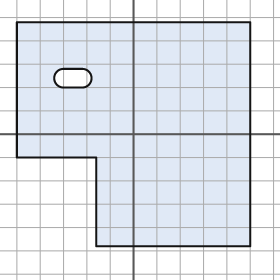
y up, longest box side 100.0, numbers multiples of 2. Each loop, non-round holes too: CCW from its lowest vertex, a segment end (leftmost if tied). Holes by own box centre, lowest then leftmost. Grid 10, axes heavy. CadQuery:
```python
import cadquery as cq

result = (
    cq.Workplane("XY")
    .moveTo(-16.0, -48.0)
    .lineTo(50.0, -48.0)
    .lineTo(50.0, 48.0)
    .lineTo(-50.0, 48.0)
    .lineTo(-50.0, -10.0)
    .lineTo(-16.0, -10.0)
    .close()
    .moveTo(-30.0, 20.0)
    .lineTo(-22.0, 20.0)
    .threePointArc((-18.0, 24.0), (-22.0, 28.0))
    .lineTo(-30.0, 28.0)
    .threePointArc((-34.0, 24.0), (-30.0, 20.0))
    .close()
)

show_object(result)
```